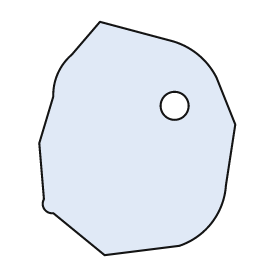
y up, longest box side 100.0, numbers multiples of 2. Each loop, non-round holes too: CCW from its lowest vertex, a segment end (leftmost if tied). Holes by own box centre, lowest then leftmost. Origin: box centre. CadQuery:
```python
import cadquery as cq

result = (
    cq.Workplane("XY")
    .moveTo(-14.0, -50.0)
    .lineTo(18.0, -46.0)
    .threePointArc((32.0, -36.0), (38.0, -20.0))
    .lineTo(42.0, 6.0)
    .lineTo(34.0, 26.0)
    .threePointArc((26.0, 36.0), (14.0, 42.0))
    .lineTo(-16.0, 50.0)
    .lineTo(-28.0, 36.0)
    .threePointArc((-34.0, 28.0), (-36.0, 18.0))
    .lineTo(-42.0, -2.0)
    .lineTo(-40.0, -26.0)
    .threePointArc((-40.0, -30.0), (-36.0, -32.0))
    .close()
    .moveTo(16.0, 14.0)
    .circle(6.0)
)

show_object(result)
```